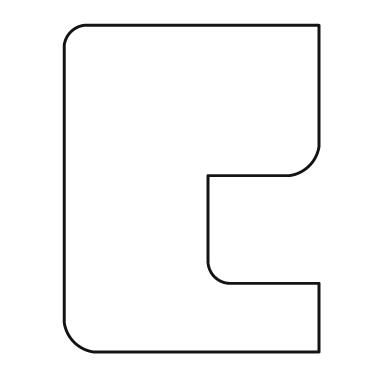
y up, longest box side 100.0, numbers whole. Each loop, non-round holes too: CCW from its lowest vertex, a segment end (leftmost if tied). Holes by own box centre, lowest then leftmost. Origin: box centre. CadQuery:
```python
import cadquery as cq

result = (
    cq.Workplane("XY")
    .moveTo(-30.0, -50.0)
    .lineTo(39.0, -50.0)
    .lineTo(39.0, -29.0)
    .lineTo(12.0, -29.0)
    .threePointArc((7.0, -27.0), (5.0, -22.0))
    .lineTo(5.0, 4.0)
    .lineTo(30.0, 4.0)
    .threePointArc((36.0, 7.0), (39.0, 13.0))
    .lineTo(39.0, 50.0)
    .lineTo(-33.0, 50.0)
    .threePointArc((-37.0, 48.0), (-39.0, 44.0))
    .lineTo(-39.0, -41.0)
    .threePointArc((-36.0, -47.0), (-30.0, -50.0))
    .close()
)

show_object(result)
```